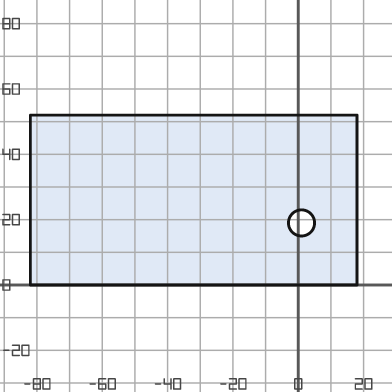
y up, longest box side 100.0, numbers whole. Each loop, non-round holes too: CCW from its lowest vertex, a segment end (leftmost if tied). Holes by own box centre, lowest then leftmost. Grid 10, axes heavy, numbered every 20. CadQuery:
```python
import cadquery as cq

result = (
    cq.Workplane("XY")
    .moveTo(-82.0, 0.0)
    .lineTo(18.0, 0.0)
    .lineTo(18.0, 52.0)
    .lineTo(-82.0, 52.0)
    .close()
    .moveTo(1.0, 19.0)
    .circle(4.0)
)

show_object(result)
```